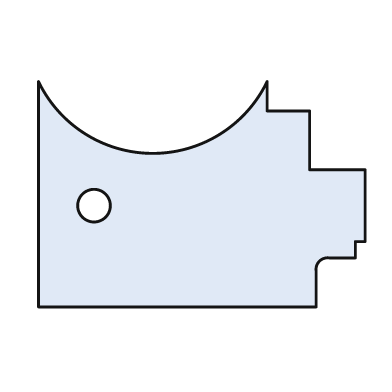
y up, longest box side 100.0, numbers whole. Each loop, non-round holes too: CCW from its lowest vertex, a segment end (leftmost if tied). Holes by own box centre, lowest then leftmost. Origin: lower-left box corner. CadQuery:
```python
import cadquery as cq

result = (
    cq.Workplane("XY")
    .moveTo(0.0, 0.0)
    .lineTo(85.0, 0.0)
    .lineTo(85.0, 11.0)
    .threePointArc((86.0, 14.0), (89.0, 15.0))
    .lineTo(97.0, 15.0)
    .lineTo(97.0, 20.0)
    .lineTo(100.0, 20.0)
    .lineTo(100.0, 42.0)
    .lineTo(83.0, 42.0)
    .lineTo(83.0, 60.0)
    .lineTo(70.0, 60.0)
    .lineTo(70.0, 69.0)
    .threePointArc((35.0, 47.0), (0.0, 69.0))
    .close()
    .moveTo(17.0, 31.0)
    .circle(5.0)
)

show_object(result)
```